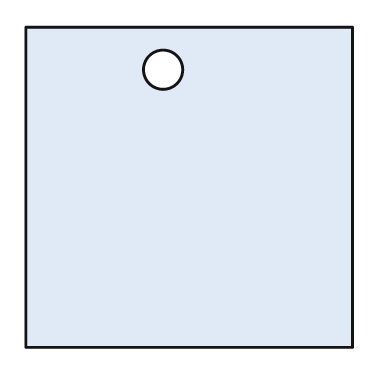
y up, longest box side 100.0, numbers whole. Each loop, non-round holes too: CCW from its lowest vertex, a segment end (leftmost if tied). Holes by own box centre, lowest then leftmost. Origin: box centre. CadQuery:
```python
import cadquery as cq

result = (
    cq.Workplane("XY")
    .moveTo(-50.0, -49.0)
    .lineTo(50.0, -49.0)
    .lineTo(50.0, 49.0)
    .lineTo(-50.0, 49.0)
    .close()
    .moveTo(-8.0, 36.0)
    .circle(6.0)
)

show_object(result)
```